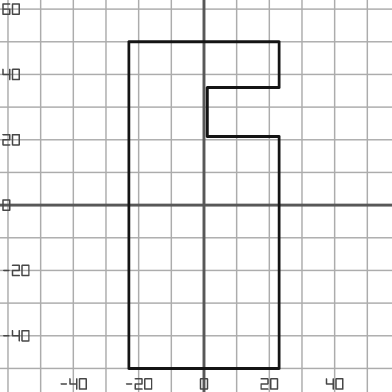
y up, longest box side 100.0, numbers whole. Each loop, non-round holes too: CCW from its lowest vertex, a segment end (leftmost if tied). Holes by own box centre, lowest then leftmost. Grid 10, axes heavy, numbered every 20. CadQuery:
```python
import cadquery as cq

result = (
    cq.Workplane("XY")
    .moveTo(-23.0, -50.0)
    .lineTo(23.0, -50.0)
    .lineTo(23.0, 21.0)
    .lineTo(1.0, 21.0)
    .lineTo(1.0, 36.0)
    .lineTo(23.0, 36.0)
    .lineTo(23.0, 50.0)
    .lineTo(-23.0, 50.0)
    .close()
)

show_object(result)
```